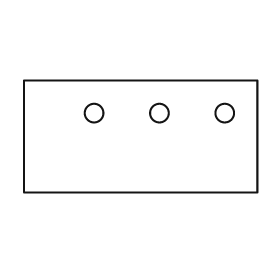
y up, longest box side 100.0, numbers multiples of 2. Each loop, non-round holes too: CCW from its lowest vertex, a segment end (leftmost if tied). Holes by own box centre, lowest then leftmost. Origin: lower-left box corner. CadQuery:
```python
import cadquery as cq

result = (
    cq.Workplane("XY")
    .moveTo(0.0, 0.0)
    .lineTo(100.0, 0.0)
    .lineTo(100.0, 48.0)
    .lineTo(0.0, 48.0)
    .close()
    .moveTo(30.0, 34.0)
    .circle(4.0)
    .moveTo(58.0, 34.0)
    .circle(4.0)
    .moveTo(86.0, 34.0)
    .circle(4.0)
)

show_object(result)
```